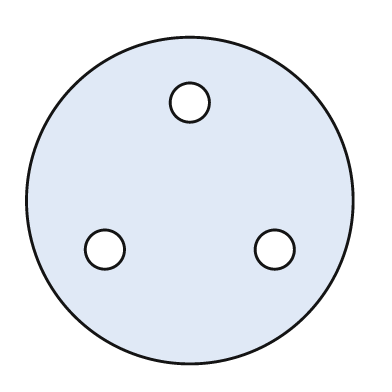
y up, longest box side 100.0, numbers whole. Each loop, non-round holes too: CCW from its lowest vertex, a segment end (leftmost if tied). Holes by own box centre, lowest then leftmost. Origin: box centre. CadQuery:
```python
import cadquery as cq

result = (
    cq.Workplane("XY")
    .moveTo(0.0, 0.0)
    .circle(50.0)
    .moveTo(-26.0, -15.0)
    .circle(6.0)
    .moveTo(26.0, -15.0)
    .circle(6.0)
    .moveTo(0.0, 30.0)
    .circle(6.0)
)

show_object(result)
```